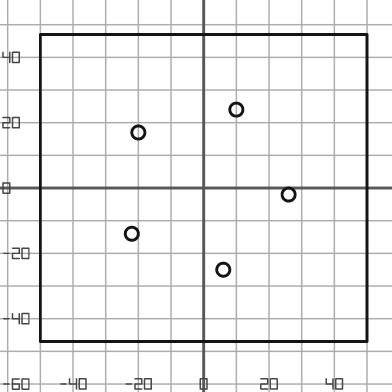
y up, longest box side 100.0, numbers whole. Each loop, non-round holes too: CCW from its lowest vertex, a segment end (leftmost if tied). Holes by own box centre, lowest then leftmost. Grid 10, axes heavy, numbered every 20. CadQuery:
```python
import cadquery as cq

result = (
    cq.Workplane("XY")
    .moveTo(-50.0, -47.0)
    .lineTo(50.0, -47.0)
    .lineTo(50.0, 47.0)
    .lineTo(-50.0, 47.0)
    .close()
    .moveTo(6.0, -25.0)
    .circle(2.0)
    .moveTo(-22.0, -14.0)
    .circle(2.0)
    .moveTo(26.0, -2.0)
    .circle(2.0)
    .moveTo(-20.0, 17.0)
    .circle(2.0)
    .moveTo(10.0, 24.0)
    .circle(2.0)
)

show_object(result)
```